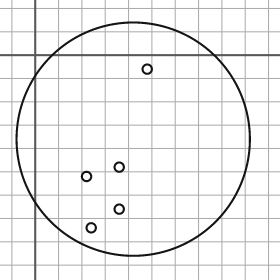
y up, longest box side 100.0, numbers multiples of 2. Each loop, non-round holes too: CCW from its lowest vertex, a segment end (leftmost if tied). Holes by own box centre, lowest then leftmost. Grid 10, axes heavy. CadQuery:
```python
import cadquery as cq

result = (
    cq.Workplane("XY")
    .moveTo(42.0, -36.0)
    .circle(50.0)
    .moveTo(24.0, -74.0)
    .circle(2.0)
    .moveTo(36.0, -66.0)
    .circle(2.0)
    .moveTo(22.0, -52.0)
    .circle(2.0)
    .moveTo(36.0, -48.0)
    .circle(2.0)
    .moveTo(48.0, -6.0)
    .circle(2.0)
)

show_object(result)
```